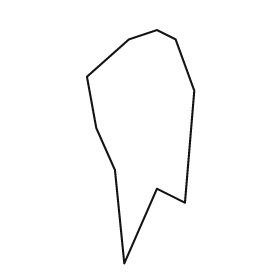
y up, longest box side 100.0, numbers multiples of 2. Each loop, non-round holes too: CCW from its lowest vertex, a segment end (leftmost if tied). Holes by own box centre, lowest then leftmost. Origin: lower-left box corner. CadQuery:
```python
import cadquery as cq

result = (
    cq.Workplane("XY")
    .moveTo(16.0, 0.0)
    .lineTo(30.0, 32.0)
    .lineTo(42.0, 26.0)
    .lineTo(46.0, 74.0)
    .lineTo(38.0, 96.0)
    .lineTo(30.0, 100.0)
    .lineTo(18.0, 96.0)
    .lineTo(0.0, 80.0)
    .lineTo(4.0, 58.0)
    .lineTo(12.0, 40.0)
    .close()
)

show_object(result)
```